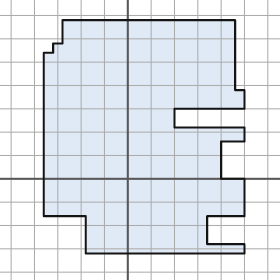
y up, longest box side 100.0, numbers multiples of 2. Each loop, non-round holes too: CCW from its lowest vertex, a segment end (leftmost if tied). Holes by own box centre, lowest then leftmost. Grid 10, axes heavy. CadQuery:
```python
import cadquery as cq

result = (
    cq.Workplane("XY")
    .moveTo(-18.0, -32.0)
    .lineTo(50.0, -32.0)
    .lineTo(50.0, -28.0)
    .lineTo(34.0, -28.0)
    .lineTo(34.0, -16.0)
    .lineTo(50.0, -16.0)
    .lineTo(50.0, 0.0)
    .lineTo(40.0, 0.0)
    .lineTo(40.0, 16.0)
    .lineTo(50.0, 16.0)
    .lineTo(50.0, 22.0)
    .lineTo(20.0, 22.0)
    .lineTo(20.0, 30.0)
    .lineTo(50.0, 30.0)
    .lineTo(50.0, 38.0)
    .lineTo(46.0, 38.0)
    .lineTo(46.0, 68.0)
    .lineTo(-28.0, 68.0)
    .lineTo(-28.0, 58.0)
    .lineTo(-32.0, 58.0)
    .lineTo(-32.0, 54.0)
    .lineTo(-36.0, 54.0)
    .lineTo(-36.0, -16.0)
    .lineTo(-18.0, -16.0)
    .close()
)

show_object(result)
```